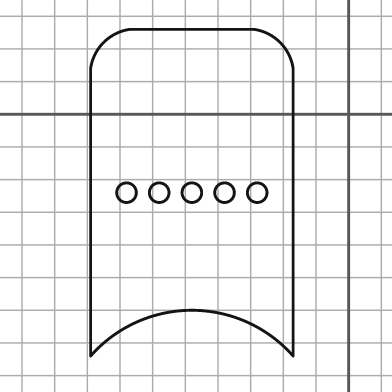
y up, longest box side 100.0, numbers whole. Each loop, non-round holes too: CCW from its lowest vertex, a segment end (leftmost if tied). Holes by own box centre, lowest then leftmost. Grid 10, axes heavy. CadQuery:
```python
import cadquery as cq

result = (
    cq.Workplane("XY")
    .moveTo(-79.0, -74.0)
    .threePointArc((-48.0, -60.0), (-17.0, -74.0))
    .lineTo(-17.0, 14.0)
    .threePointArc((-21.0, 22.0), (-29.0, 26.0))
    .lineTo(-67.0, 26.0)
    .threePointArc((-75.0, 22.0), (-79.0, 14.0))
    .close()
    .moveTo(-68.0, -24.0)
    .circle(3.0)
    .moveTo(-58.0, -24.0)
    .circle(3.0)
    .moveTo(-48.0, -24.0)
    .circle(3.0)
    .moveTo(-38.0, -24.0)
    .circle(3.0)
    .moveTo(-28.0, -24.0)
    .circle(3.0)
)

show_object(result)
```